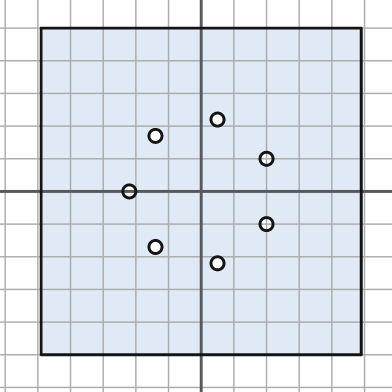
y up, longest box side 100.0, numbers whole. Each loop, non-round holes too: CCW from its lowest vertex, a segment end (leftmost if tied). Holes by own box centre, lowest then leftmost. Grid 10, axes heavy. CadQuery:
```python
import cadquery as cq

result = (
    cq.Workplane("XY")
    .moveTo(-49.0, -50.0)
    .lineTo(49.0, -50.0)
    .lineTo(49.0, 50.0)
    .lineTo(-49.0, 50.0)
    .close()
    .moveTo(5.0, -22.0)
    .circle(2.0)
    .moveTo(-14.0, -17.0)
    .circle(2.0)
    .moveTo(20.0, -10.0)
    .circle(2.0)
    .moveTo(-22.0, 0.0)
    .circle(2.0)
    .moveTo(20.0, 10.0)
    .circle(2.0)
    .moveTo(-14.0, 17.0)
    .circle(2.0)
    .moveTo(5.0, 22.0)
    .circle(2.0)
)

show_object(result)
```